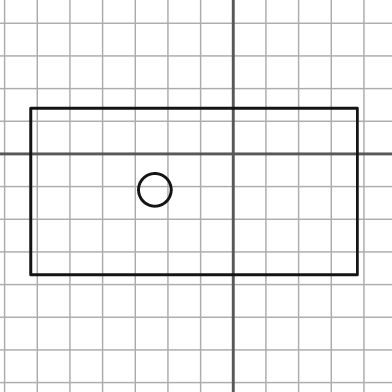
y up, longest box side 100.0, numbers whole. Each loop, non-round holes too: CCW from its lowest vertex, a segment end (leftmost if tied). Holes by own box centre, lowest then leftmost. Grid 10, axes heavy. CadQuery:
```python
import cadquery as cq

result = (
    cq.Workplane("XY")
    .moveTo(-62.0, -37.0)
    .lineTo(38.0, -37.0)
    .lineTo(38.0, 14.0)
    .lineTo(-62.0, 14.0)
    .close()
    .moveTo(-24.0, -11.0)
    .circle(5.0)
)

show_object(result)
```